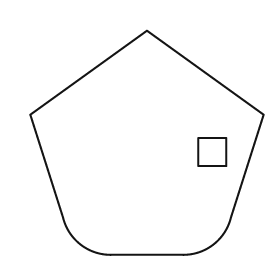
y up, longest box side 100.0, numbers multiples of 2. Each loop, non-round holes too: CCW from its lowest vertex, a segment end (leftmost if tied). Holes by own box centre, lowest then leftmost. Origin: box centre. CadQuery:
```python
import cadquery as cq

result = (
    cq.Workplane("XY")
    .moveTo(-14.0, -48.0)
    .lineTo(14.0, -48.0)
    .threePointArc((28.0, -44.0), (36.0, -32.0))
    .lineTo(50.0, 12.0)
    .lineTo(0.0, 48.0)
    .lineTo(-50.0, 12.0)
    .lineTo(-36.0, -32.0)
    .threePointArc((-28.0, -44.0), (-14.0, -48.0))
    .close()
    .moveTo(22.0, -10.0)
    .lineTo(34.0, -10.0)
    .lineTo(34.0, 2.0)
    .lineTo(22.0, 2.0)
    .close()
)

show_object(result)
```